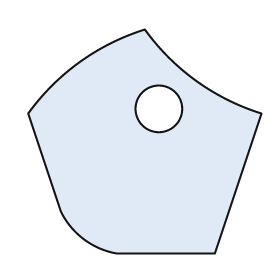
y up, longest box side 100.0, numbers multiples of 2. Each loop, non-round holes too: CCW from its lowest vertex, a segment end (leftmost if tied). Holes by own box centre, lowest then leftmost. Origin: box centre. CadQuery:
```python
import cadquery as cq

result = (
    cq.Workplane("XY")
    .moveTo(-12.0, -48.0)
    .lineTo(30.0, -48.0)
    .lineTo(50.0, 12.0)
    .threePointArc((22.0, 26.0), (0.0, 48.0))
    .threePointArc((-28.0, 34.0), (-50.0, 12.0))
    .lineTo(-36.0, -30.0)
    .threePointArc((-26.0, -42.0), (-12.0, -48.0))
    .close()
    .moveTo(6.0, 14.0)
    .circle(10.0)
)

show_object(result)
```